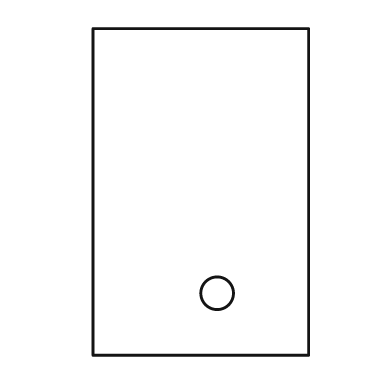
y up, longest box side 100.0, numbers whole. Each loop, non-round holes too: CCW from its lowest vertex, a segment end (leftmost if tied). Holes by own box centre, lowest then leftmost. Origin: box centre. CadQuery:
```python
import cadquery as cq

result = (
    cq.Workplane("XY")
    .moveTo(-33.0, -50.0)
    .lineTo(33.0, -50.0)
    .lineTo(33.0, 50.0)
    .lineTo(-33.0, 50.0)
    .close()
    .moveTo(5.0, -31.0)
    .circle(5.0)
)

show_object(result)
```